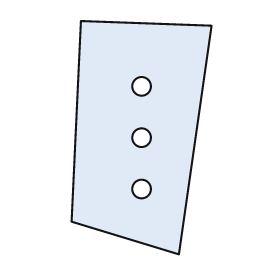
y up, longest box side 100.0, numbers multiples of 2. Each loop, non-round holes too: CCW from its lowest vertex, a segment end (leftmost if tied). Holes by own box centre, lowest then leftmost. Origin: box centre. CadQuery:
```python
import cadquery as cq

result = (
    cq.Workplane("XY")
    .moveTo(16.0, -50.0)
    .lineTo(30.0, 48.0)
    .lineTo(-26.0, 50.0)
    .lineTo(-30.0, -36.0)
    .close()
    .moveTo(0.0, -22.0)
    .circle(4.0)
    .moveTo(0.0, 0.0)
    .circle(4.0)
    .moveTo(0.0, 22.0)
    .circle(4.0)
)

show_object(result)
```